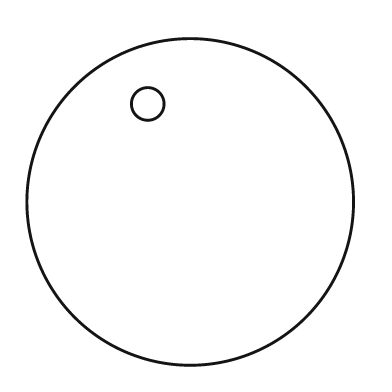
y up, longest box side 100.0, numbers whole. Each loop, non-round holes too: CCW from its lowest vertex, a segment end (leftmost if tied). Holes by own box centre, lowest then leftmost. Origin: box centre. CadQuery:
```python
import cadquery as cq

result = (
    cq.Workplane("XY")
    .moveTo(0.0, 0.0)
    .circle(50.0)
    .moveTo(-13.0, 30.0)
    .circle(5.0)
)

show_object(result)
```